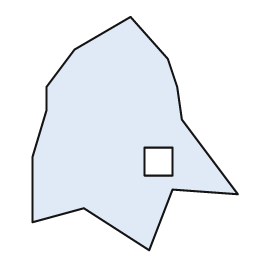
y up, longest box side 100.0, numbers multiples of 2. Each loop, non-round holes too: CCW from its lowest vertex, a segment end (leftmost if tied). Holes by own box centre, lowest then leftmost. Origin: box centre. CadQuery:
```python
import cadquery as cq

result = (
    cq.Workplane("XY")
    .moveTo(6.0, -50.0)
    .lineTo(16.0, -24.0)
    .lineTo(44.0, -26.0)
    .lineTo(20.0, 6.0)
    .lineTo(18.0, 20.0)
    .lineTo(14.0, 32.0)
    .lineTo(-2.0, 50.0)
    .lineTo(-26.0, 36.0)
    .lineTo(-38.0, 20.0)
    .lineTo(-38.0, 10.0)
    .lineTo(-44.0, -10.0)
    .lineTo(-44.0, -38.0)
    .lineTo(-22.0, -32.0)
    .close()
    .moveTo(4.0, -18.0)
    .lineTo(16.0, -18.0)
    .lineTo(16.0, -6.0)
    .lineTo(4.0, -6.0)
    .close()
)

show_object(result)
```